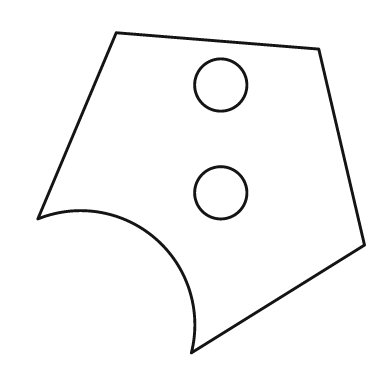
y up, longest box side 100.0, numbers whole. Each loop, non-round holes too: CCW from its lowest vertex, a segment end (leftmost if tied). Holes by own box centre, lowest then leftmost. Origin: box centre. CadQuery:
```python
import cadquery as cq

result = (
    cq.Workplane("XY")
    .moveTo(-3.0, -49.0)
    .lineTo(50.0, -16.0)
    .lineTo(36.0, 44.0)
    .lineTo(-26.0, 49.0)
    .lineTo(-50.0, -8.0)
    .threePointArc((-14.0, -14.0), (-3.0, -49.0))
    .close()
    .moveTo(6.0, 0.0)
    .circle(8.0)
    .moveTo(6.0, 33.0)
    .circle(8.0)
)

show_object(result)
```